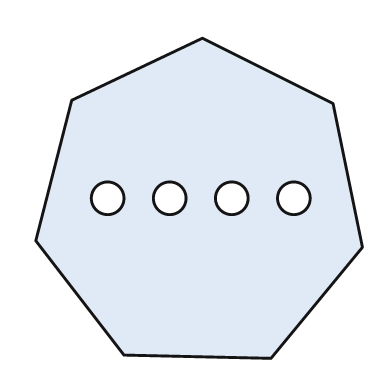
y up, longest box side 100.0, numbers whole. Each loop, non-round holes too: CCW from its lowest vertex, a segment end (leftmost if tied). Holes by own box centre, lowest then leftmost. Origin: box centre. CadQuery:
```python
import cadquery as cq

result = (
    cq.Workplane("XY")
    .moveTo(22.0, -49.0)
    .lineTo(50.0, -15.0)
    .lineTo(41.0, 29.0)
    .lineTo(1.0, 49.0)
    .lineTo(-39.0, 30.0)
    .lineTo(-50.0, -13.0)
    .lineTo(-23.0, -48.0)
    .close()
    .moveTo(-28.0, 0.0)
    .circle(5.0)
    .moveTo(-9.0, 0.0)
    .circle(5.0)
    .moveTo(10.0, 0.0)
    .circle(5.0)
    .moveTo(29.0, 0.0)
    .circle(5.0)
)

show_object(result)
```